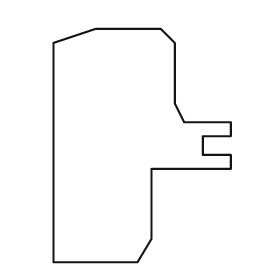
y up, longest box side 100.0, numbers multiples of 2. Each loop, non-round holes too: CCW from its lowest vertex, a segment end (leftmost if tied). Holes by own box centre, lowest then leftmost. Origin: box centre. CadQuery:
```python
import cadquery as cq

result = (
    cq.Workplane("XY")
    .moveTo(-38.0, -50.0)
    .lineTo(-2.0, -50.0)
    .lineTo(4.0, -40.0)
    .lineTo(4.0, -10.0)
    .lineTo(38.0, -10.0)
    .lineTo(38.0, -4.0)
    .lineTo(26.0, -4.0)
    .lineTo(26.0, 4.0)
    .lineTo(38.0, 4.0)
    .lineTo(38.0, 10.0)
    .lineTo(18.0, 10.0)
    .lineTo(14.0, 18.0)
    .lineTo(14.0, 44.0)
    .lineTo(8.0, 50.0)
    .lineTo(-20.0, 50.0)
    .lineTo(-38.0, 44.0)
    .close()
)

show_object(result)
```